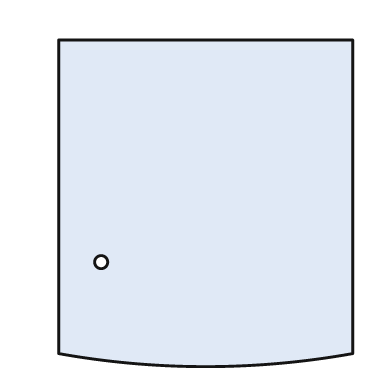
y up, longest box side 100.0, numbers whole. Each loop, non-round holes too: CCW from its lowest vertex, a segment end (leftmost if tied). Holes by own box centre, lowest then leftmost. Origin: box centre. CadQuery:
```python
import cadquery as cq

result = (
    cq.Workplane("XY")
    .moveTo(-45.0, -46.0)
    .threePointArc((0.0, -50.0), (45.0, -46.0))
    .lineTo(45.0, 50.0)
    .lineTo(-45.0, 50.0)
    .close()
    .moveTo(-32.0, -18.0)
    .circle(2.0)
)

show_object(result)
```